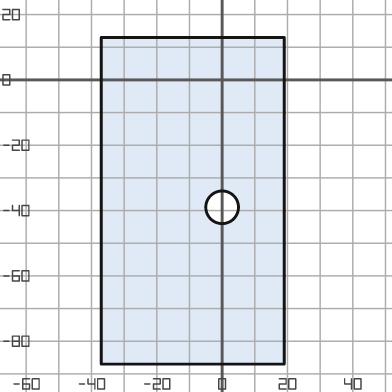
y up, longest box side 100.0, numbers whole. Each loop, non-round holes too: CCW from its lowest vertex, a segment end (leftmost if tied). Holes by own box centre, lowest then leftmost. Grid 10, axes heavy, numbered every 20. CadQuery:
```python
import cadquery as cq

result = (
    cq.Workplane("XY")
    .moveTo(-37.0, -87.0)
    .lineTo(19.0, -87.0)
    .lineTo(19.0, 13.0)
    .lineTo(-37.0, 13.0)
    .close()
    .moveTo(0.0, -39.0)
    .circle(5.0)
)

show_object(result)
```